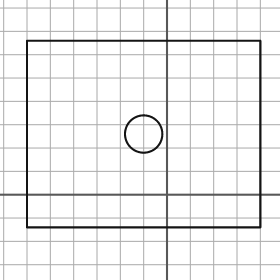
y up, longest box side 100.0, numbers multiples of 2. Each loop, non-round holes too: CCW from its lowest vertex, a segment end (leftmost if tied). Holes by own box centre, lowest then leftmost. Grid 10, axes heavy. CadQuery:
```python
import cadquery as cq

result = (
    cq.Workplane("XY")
    .moveTo(-60.0, -14.0)
    .lineTo(40.0, -14.0)
    .lineTo(40.0, 66.0)
    .lineTo(-60.0, 66.0)
    .close()
    .moveTo(-10.0, 26.0)
    .circle(8.0)
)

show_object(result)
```